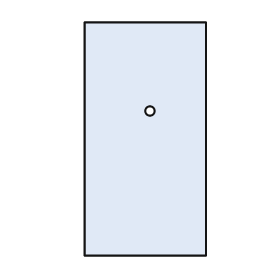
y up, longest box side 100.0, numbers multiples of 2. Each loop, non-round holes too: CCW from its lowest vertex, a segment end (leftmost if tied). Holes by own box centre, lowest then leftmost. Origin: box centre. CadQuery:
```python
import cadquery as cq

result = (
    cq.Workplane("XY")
    .moveTo(-26.0, -50.0)
    .lineTo(26.0, -50.0)
    .lineTo(26.0, 50.0)
    .lineTo(-26.0, 50.0)
    .close()
    .moveTo(2.0, 12.0)
    .circle(2.0)
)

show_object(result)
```